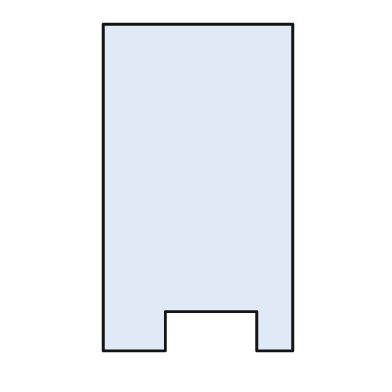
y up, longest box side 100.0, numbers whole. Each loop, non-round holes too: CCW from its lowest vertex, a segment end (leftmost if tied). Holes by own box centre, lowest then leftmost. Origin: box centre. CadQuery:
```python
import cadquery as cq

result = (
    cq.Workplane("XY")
    .moveTo(-29.0, -50.0)
    .lineTo(-10.0, -50.0)
    .lineTo(-10.0, -38.0)
    .lineTo(18.0, -38.0)
    .lineTo(18.0, -50.0)
    .lineTo(29.0, -50.0)
    .lineTo(29.0, 50.0)
    .lineTo(-29.0, 50.0)
    .close()
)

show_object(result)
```